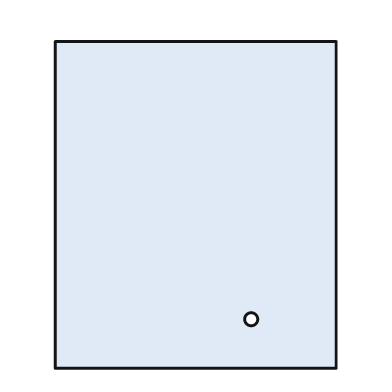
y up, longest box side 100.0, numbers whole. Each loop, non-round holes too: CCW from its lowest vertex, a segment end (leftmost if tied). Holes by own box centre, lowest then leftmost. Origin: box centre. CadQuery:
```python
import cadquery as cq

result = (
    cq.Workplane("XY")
    .moveTo(-43.0, -50.0)
    .lineTo(43.0, -50.0)
    .lineTo(43.0, 50.0)
    .lineTo(-43.0, 50.0)
    .close()
    .moveTo(17.0, -35.0)
    .circle(2.0)
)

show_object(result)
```